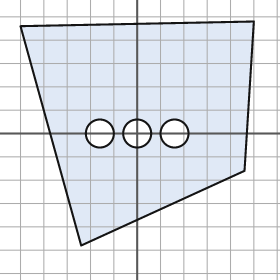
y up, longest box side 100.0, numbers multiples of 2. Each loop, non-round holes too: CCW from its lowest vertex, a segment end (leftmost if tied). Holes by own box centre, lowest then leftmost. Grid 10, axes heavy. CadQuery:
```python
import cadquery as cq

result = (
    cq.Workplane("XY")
    .moveTo(-24.0, -48.0)
    .lineTo(46.0, -16.0)
    .lineTo(50.0, 48.0)
    .lineTo(-50.0, 46.0)
    .close()
    .moveTo(-16.0, 0.0)
    .circle(6.0)
    .moveTo(0.0, 0.0)
    .circle(6.0)
    .moveTo(16.0, 0.0)
    .circle(6.0)
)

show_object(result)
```